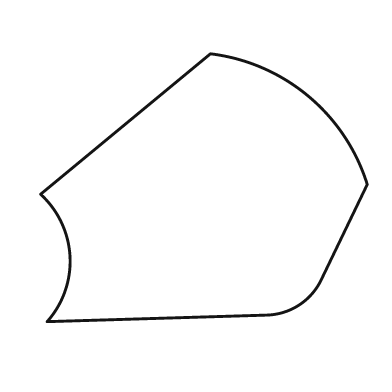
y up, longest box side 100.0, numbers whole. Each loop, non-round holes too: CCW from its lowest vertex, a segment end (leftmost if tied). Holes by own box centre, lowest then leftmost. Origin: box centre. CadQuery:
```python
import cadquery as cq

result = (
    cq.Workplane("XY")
    .moveTo(-48.0, -41.0)
    .lineTo(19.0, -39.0)
    .threePointArc((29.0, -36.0), (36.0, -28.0))
    .lineTo(50.0, 1.0)
    .threePointArc((32.0, 28.0), (2.0, 41.0))
    .lineTo(-50.0, -2.0)
    .threePointArc((-41.0, -21.0), (-48.0, -41.0))
    .close()
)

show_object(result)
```